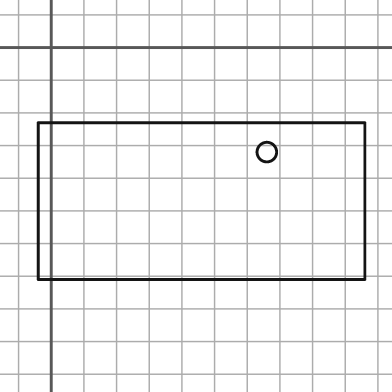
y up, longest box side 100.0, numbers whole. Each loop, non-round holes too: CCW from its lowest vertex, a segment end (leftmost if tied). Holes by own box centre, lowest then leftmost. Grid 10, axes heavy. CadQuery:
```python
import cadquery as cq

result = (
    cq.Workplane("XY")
    .moveTo(-4.0, -71.0)
    .lineTo(96.0, -71.0)
    .lineTo(96.0, -23.0)
    .lineTo(-4.0, -23.0)
    .close()
    .moveTo(66.0, -32.0)
    .circle(3.0)
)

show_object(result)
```